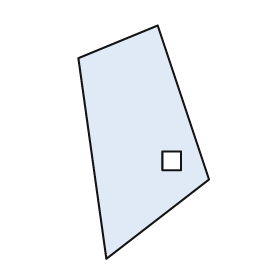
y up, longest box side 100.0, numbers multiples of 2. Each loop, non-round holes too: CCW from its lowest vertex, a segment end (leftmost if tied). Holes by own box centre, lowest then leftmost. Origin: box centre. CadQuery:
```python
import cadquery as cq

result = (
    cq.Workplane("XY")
    .moveTo(-16.0, -50.0)
    .lineTo(28.0, -16.0)
    .lineTo(6.0, 50.0)
    .lineTo(-28.0, 36.0)
    .close()
    .moveTo(8.0, -12.0)
    .lineTo(16.0, -12.0)
    .lineTo(16.0, -4.0)
    .lineTo(8.0, -4.0)
    .close()
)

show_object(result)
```